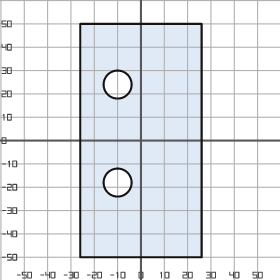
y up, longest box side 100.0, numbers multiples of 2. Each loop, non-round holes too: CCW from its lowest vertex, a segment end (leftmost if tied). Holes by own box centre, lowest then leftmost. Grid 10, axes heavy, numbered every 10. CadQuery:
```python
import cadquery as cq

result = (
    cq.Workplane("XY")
    .moveTo(-26.0, -50.0)
    .lineTo(26.0, -50.0)
    .lineTo(26.0, 50.0)
    .lineTo(-26.0, 50.0)
    .close()
    .moveTo(-10.0, -18.0)
    .circle(6.0)
    .moveTo(-10.0, 24.0)
    .circle(6.0)
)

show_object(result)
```